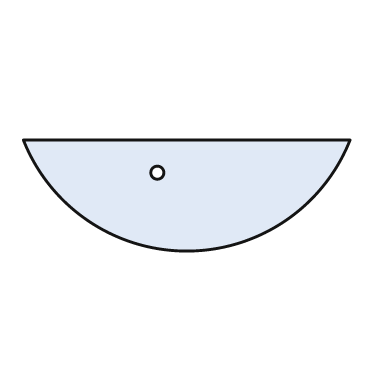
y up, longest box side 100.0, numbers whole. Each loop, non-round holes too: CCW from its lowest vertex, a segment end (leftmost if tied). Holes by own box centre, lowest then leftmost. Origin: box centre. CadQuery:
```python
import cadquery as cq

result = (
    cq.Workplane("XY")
    .moveTo(-50.0, 17.0)
    .threePointArc((0.0, -17.0), (50.0, 17.0))
    .close()
    .moveTo(-9.0, 7.0)
    .circle(2.0)
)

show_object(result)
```